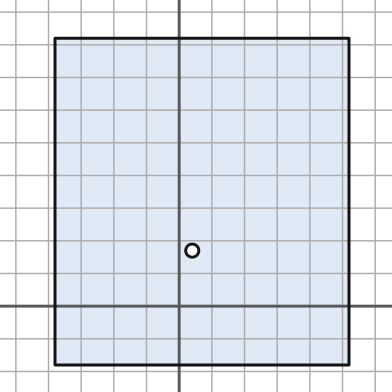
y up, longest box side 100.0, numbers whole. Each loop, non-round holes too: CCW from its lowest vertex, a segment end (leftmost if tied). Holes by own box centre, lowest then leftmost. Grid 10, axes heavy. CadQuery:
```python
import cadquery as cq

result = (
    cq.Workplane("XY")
    .moveTo(-38.0, -18.0)
    .lineTo(52.0, -18.0)
    .lineTo(52.0, 82.0)
    .lineTo(-38.0, 82.0)
    .close()
    .moveTo(4.0, 17.0)
    .circle(2.0)
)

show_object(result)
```